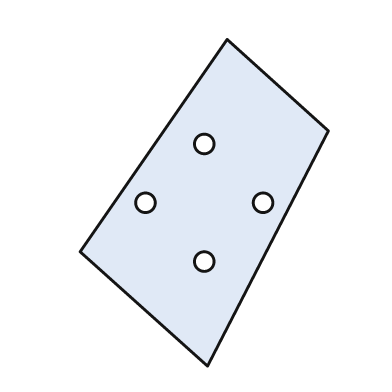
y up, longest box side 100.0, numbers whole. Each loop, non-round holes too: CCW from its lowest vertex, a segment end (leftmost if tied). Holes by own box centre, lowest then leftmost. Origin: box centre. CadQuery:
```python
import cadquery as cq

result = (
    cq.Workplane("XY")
    .moveTo(1.0, -50.0)
    .lineTo(38.0, 22.0)
    .lineTo(7.0, 50.0)
    .lineTo(-38.0, -15.0)
    .close()
    .moveTo(0.0, -18.0)
    .circle(3.0)
    .moveTo(-18.0, 0.0)
    .circle(3.0)
    .moveTo(18.0, 0.0)
    .circle(3.0)
    .moveTo(0.0, 18.0)
    .circle(3.0)
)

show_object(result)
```